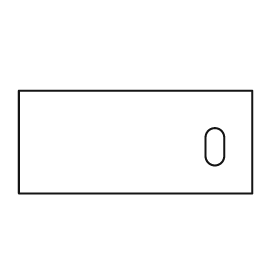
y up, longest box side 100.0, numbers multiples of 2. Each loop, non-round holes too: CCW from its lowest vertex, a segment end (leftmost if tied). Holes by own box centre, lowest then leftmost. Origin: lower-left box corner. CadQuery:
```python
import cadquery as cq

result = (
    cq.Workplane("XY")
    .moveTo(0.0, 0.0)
    .lineTo(100.0, 0.0)
    .lineTo(100.0, 44.0)
    .lineTo(0.0, 44.0)
    .close()
    .moveTo(80.0, 16.0)
    .threePointArc((84.0, 12.0), (88.0, 16.0))
    .lineTo(88.0, 24.0)
    .threePointArc((84.0, 28.0), (80.0, 24.0))
    .close()
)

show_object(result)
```